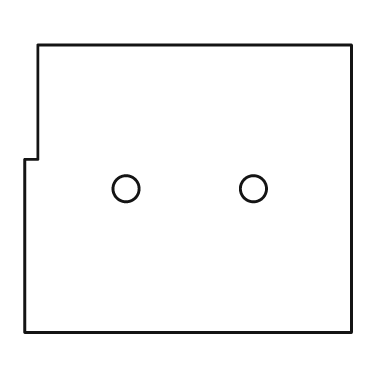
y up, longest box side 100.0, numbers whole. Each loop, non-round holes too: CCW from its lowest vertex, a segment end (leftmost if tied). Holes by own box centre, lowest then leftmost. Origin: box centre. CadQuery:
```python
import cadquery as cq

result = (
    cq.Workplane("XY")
    .moveTo(-50.0, -44.0)
    .lineTo(50.0, -44.0)
    .lineTo(50.0, 44.0)
    .lineTo(-46.0, 44.0)
    .lineTo(-46.0, 9.0)
    .lineTo(-50.0, 9.0)
    .close()
    .moveTo(-19.0, 0.0)
    .circle(4.0)
    .moveTo(20.0, 0.0)
    .circle(4.0)
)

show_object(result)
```